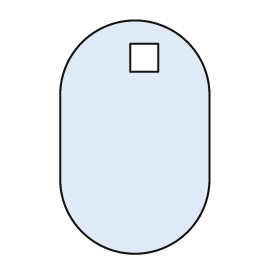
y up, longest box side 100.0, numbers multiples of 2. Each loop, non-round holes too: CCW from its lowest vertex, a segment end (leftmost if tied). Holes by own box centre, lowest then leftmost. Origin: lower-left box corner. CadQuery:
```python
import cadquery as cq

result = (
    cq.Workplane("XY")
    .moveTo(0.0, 32.0)
    .threePointArc((32.0, 0.0), (64.0, 32.0))
    .lineTo(64.0, 68.0)
    .threePointArc((32.0, 100.0), (0.0, 68.0))
    .close()
    .moveTo(30.0, 78.0)
    .lineTo(42.0, 78.0)
    .lineTo(42.0, 90.0)
    .lineTo(30.0, 90.0)
    .close()
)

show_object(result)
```